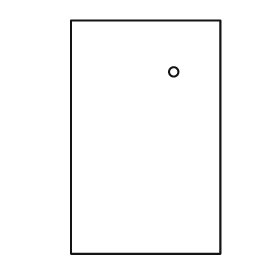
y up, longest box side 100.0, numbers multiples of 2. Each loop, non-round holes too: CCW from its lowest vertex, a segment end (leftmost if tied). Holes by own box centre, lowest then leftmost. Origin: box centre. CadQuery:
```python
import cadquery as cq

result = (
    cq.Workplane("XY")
    .moveTo(-32.0, -50.0)
    .lineTo(32.0, -50.0)
    .lineTo(32.0, 50.0)
    .lineTo(-32.0, 50.0)
    .close()
    .moveTo(12.0, 28.0)
    .circle(2.0)
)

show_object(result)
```